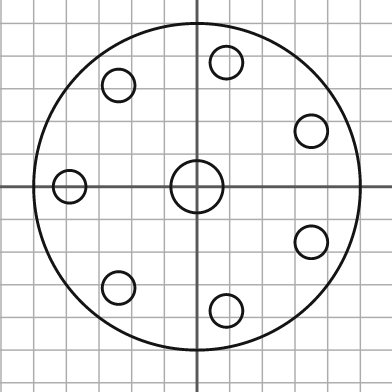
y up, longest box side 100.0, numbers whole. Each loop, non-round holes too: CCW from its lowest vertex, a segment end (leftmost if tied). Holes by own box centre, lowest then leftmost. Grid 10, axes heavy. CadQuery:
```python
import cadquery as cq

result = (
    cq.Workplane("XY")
    .moveTo(0.0, 0.0)
    .circle(50.0)
    .moveTo(9.0, -38.0)
    .circle(5.0)
    .moveTo(-24.0, -31.0)
    .circle(5.0)
    .moveTo(35.0, -17.0)
    .circle(5.0)
    .moveTo(-39.0, 0.0)
    .circle(5.0)
    .moveTo(0.0, 0.0)
    .circle(8.0)
    .moveTo(35.0, 17.0)
    .circle(5.0)
    .moveTo(-24.0, 31.0)
    .circle(5.0)
    .moveTo(9.0, 38.0)
    .circle(5.0)
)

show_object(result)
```